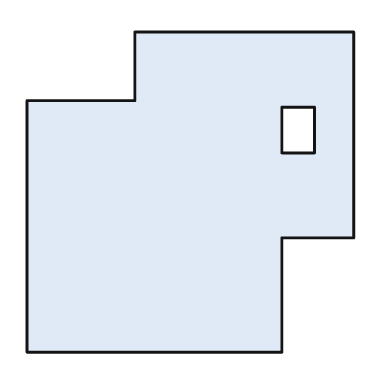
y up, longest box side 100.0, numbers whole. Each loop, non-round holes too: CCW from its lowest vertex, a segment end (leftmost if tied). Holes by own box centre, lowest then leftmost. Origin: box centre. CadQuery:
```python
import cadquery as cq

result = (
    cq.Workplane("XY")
    .moveTo(-50.0, -49.0)
    .lineTo(28.0, -49.0)
    .lineTo(28.0, -14.0)
    .lineTo(50.0, -14.0)
    .lineTo(50.0, 49.0)
    .lineTo(-17.0, 49.0)
    .lineTo(-17.0, 28.0)
    .lineTo(-50.0, 28.0)
    .close()
    .moveTo(28.0, 12.0)
    .lineTo(38.0, 12.0)
    .lineTo(38.0, 26.0)
    .lineTo(28.0, 26.0)
    .close()
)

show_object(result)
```